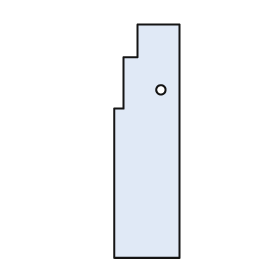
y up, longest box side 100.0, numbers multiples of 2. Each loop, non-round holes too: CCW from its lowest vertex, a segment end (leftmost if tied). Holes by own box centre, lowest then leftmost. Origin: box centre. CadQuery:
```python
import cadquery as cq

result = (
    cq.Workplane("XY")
    .moveTo(-14.0, -50.0)
    .lineTo(14.0, -50.0)
    .lineTo(14.0, 50.0)
    .lineTo(-4.0, 50.0)
    .lineTo(-4.0, 36.0)
    .lineTo(-10.0, 36.0)
    .lineTo(-10.0, 14.0)
    .lineTo(-14.0, 14.0)
    .close()
    .moveTo(6.0, 22.0)
    .circle(2.0)
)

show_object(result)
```